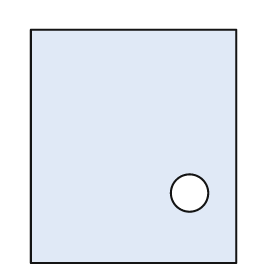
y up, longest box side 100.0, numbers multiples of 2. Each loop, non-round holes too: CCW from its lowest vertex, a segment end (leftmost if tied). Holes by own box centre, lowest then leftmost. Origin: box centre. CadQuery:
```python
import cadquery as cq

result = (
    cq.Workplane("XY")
    .moveTo(-44.0, -50.0)
    .lineTo(44.0, -50.0)
    .lineTo(44.0, 50.0)
    .lineTo(-44.0, 50.0)
    .close()
    .moveTo(24.0, -20.0)
    .circle(8.0)
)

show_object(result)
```